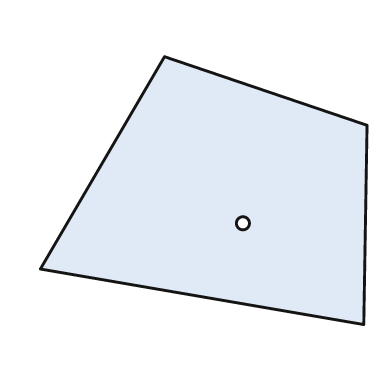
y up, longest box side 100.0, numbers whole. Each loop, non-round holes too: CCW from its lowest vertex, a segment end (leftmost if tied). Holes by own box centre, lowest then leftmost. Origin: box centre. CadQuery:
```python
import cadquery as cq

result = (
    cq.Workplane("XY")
    .moveTo(49.0, -41.0)
    .lineTo(50.0, 20.0)
    .lineTo(-12.0, 41.0)
    .lineTo(-50.0, -24.0)
    .close()
    .moveTo(12.0, -10.0)
    .circle(2.0)
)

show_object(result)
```